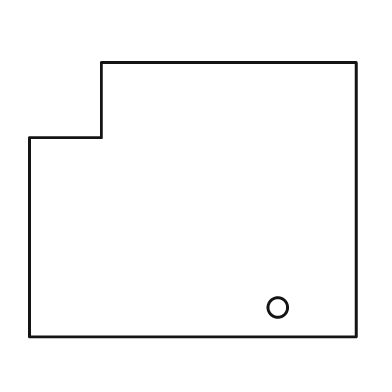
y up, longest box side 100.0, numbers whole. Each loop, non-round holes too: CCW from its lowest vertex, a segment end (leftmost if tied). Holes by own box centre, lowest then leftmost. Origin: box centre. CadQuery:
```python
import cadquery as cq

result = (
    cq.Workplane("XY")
    .moveTo(-50.0, -42.0)
    .lineTo(50.0, -42.0)
    .lineTo(50.0, 42.0)
    .lineTo(-28.0, 42.0)
    .lineTo(-28.0, 19.0)
    .lineTo(-50.0, 19.0)
    .close()
    .moveTo(26.0, -33.0)
    .circle(3.0)
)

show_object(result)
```